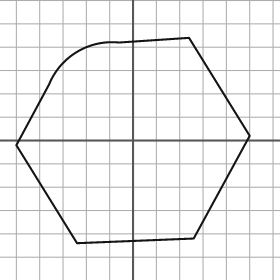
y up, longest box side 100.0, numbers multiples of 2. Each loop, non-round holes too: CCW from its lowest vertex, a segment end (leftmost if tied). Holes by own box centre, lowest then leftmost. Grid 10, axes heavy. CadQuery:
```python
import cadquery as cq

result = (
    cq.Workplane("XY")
    .moveTo(-24.0, -44.0)
    .lineTo(26.0, -42.0)
    .lineTo(50.0, 2.0)
    .lineTo(24.0, 44.0)
    .lineTo(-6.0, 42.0)
    .threePointArc((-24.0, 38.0), (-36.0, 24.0))
    .lineTo(-50.0, -2.0)
    .close()
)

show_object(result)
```